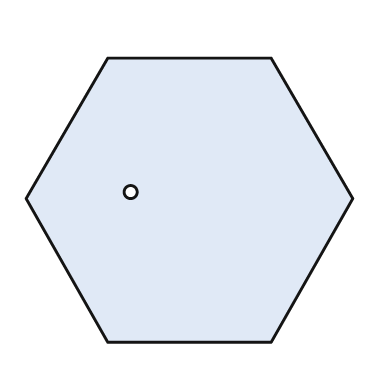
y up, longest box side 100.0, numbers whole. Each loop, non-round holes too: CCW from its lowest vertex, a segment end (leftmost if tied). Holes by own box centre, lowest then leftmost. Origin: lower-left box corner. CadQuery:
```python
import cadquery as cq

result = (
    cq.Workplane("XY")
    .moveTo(25.0, 0.0)
    .lineTo(75.0, 0.0)
    .lineTo(100.0, 44.0)
    .lineTo(75.0, 87.0)
    .lineTo(25.0, 87.0)
    .lineTo(0.0, 44.0)
    .close()
    .moveTo(32.0, 46.0)
    .circle(2.0)
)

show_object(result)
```